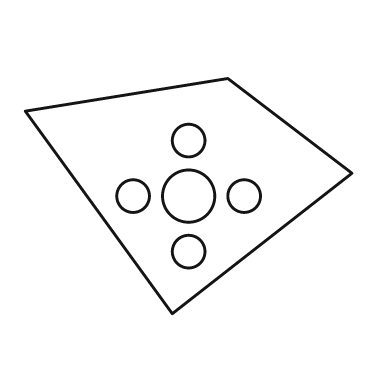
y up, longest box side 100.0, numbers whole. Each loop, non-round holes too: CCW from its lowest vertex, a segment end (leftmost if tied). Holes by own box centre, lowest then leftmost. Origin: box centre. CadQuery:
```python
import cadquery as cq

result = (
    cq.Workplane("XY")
    .moveTo(-5.0, -36.0)
    .lineTo(50.0, 7.0)
    .lineTo(12.0, 36.0)
    .lineTo(-50.0, 26.0)
    .close()
    .moveTo(0.0, -17.0)
    .circle(5.0)
    .moveTo(-17.0, 0.0)
    .circle(5.0)
    .moveTo(0.0, 0.0)
    .circle(8.0)
    .moveTo(17.0, 0.0)
    .circle(5.0)
    .moveTo(0.0, 17.0)
    .circle(5.0)
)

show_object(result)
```